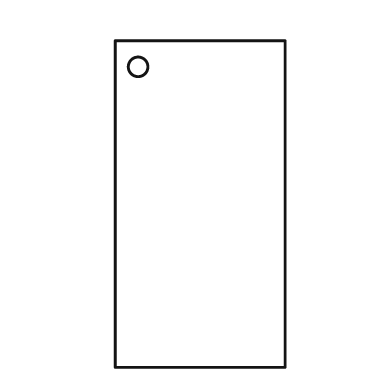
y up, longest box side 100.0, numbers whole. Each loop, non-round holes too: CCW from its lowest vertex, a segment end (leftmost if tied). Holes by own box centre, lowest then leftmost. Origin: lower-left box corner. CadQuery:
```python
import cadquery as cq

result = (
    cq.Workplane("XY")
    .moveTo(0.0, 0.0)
    .lineTo(52.0, 0.0)
    .lineTo(52.0, 100.0)
    .lineTo(0.0, 100.0)
    .close()
    .moveTo(7.0, 92.0)
    .circle(3.0)
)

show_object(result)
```